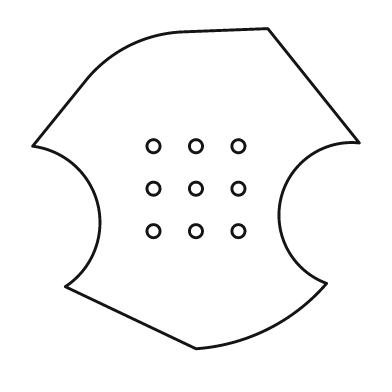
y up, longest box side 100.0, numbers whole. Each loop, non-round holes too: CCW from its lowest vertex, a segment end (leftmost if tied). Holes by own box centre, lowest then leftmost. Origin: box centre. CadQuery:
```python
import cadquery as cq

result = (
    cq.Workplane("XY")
    .moveTo(0.0, -49.0)
    .threePointArc((22.0, -43.0), (40.0, -29.0))
    .threePointArc((26.0, -3.0), (50.0, 14.0))
    .lineTo(22.0, 49.0)
    .lineTo(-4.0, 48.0)
    .threePointArc((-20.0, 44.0), (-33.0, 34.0))
    .lineTo(-50.0, 13.0)
    .threePointArc((-30.0, -5.0), (-40.0, -30.0))
    .close()
    .moveTo(-13.0, -13.0)
    .circle(2.0)
    .moveTo(0.0, -13.0)
    .circle(2.0)
    .moveTo(13.0, -13.0)
    .circle(2.0)
    .moveTo(-13.0, 0.0)
    .circle(2.0)
    .moveTo(0.0, 0.0)
    .circle(2.0)
    .moveTo(13.0, 0.0)
    .circle(2.0)
    .moveTo(-13.0, 13.0)
    .circle(2.0)
    .moveTo(0.0, 13.0)
    .circle(2.0)
    .moveTo(13.0, 13.0)
    .circle(2.0)
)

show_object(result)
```